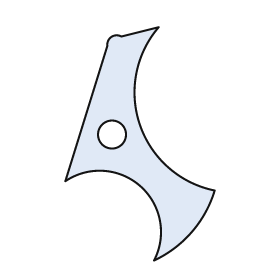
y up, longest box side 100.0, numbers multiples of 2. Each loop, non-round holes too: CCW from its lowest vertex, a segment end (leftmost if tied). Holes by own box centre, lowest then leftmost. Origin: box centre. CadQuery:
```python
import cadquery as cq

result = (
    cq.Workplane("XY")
    .moveTo(6.0, -50.0)
    .threePointArc((22.0, -38.0), (32.0, -20.0))
    .threePointArc((0.0, 8.0), (8.0, 50.0))
    .lineTo(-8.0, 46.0)
    .threePointArc((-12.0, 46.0), (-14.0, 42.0))
    .lineTo(-32.0, -16.0)
    .threePointArc((0.0, -18.0), (6.0, -50.0))
    .close()
    .moveTo(-12.0, 4.0)
    .circle(6.0)
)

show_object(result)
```